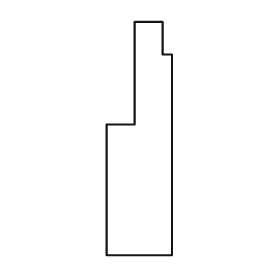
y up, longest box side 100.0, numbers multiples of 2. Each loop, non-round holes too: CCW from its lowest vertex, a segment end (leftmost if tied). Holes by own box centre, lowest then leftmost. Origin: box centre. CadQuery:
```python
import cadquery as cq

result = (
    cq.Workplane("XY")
    .moveTo(-14.0, -50.0)
    .lineTo(14.0, -50.0)
    .lineTo(14.0, 36.0)
    .lineTo(10.0, 36.0)
    .lineTo(10.0, 50.0)
    .lineTo(-2.0, 50.0)
    .lineTo(-2.0, 6.0)
    .lineTo(-14.0, 6.0)
    .close()
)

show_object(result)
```